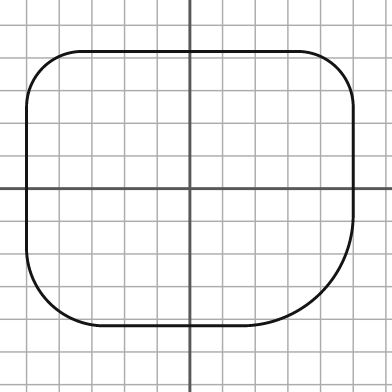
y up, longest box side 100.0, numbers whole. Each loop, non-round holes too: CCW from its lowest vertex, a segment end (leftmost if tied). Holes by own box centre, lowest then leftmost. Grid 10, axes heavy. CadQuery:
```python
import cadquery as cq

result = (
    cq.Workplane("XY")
    .moveTo(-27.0, -42.0)
    .lineTo(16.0, -42.0)
    .threePointArc((40.0, -32.0), (50.0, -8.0))
    .lineTo(50.0, 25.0)
    .threePointArc((45.0, 37.0), (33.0, 42.0))
    .lineTo(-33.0, 42.0)
    .threePointArc((-45.0, 37.0), (-50.0, 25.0))
    .lineTo(-50.0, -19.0)
    .threePointArc((-43.0, -35.0), (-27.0, -42.0))
    .close()
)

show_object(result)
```